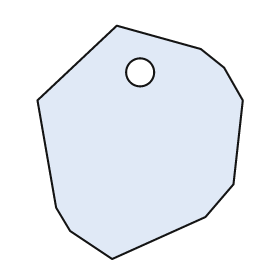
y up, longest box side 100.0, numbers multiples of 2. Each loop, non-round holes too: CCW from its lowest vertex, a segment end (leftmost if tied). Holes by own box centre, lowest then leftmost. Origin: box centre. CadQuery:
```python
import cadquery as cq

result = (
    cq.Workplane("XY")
    .moveTo(-12.0, -50.0)
    .lineTo(28.0, -32.0)
    .lineTo(40.0, -18.0)
    .lineTo(44.0, 18.0)
    .lineTo(36.0, 32.0)
    .lineTo(26.0, 40.0)
    .lineTo(-10.0, 50.0)
    .lineTo(-44.0, 18.0)
    .lineTo(-36.0, -28.0)
    .lineTo(-30.0, -38.0)
    .close()
    .moveTo(0.0, 30.0)
    .circle(6.0)
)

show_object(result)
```